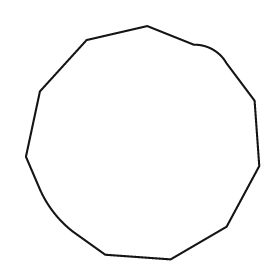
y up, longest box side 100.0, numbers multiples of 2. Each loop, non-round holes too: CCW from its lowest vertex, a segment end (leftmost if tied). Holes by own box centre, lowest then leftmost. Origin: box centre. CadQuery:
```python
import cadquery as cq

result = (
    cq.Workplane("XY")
    .moveTo(12.0, -50.0)
    .lineTo(36.0, -36.0)
    .lineTo(50.0, -10.0)
    .lineTo(48.0, 18.0)
    .lineTo(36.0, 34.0)
    .threePointArc((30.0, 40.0), (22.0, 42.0))
    .lineTo(2.0, 50.0)
    .lineTo(-24.0, 44.0)
    .lineTo(-44.0, 22.0)
    .lineTo(-50.0, -6.0)
    .lineTo(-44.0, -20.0)
    .threePointArc((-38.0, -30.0), (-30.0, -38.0))
    .lineTo(-16.0, -48.0)
    .close()
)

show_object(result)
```